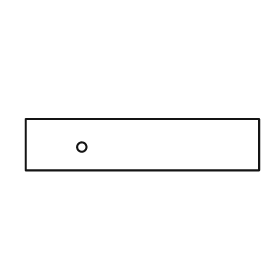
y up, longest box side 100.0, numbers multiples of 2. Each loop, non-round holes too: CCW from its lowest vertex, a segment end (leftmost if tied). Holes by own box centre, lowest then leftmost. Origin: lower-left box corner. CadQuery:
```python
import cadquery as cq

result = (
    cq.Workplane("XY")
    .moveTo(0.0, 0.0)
    .lineTo(100.0, 0.0)
    .lineTo(100.0, 22.0)
    .lineTo(0.0, 22.0)
    .close()
    .moveTo(24.0, 10.0)
    .circle(2.0)
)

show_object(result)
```